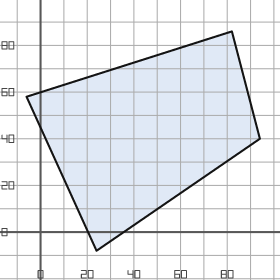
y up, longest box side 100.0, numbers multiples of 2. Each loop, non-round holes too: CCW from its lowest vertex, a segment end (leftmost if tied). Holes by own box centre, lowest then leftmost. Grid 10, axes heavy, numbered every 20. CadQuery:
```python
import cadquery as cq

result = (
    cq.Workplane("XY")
    .moveTo(24.0, -8.0)
    .lineTo(94.0, 40.0)
    .lineTo(82.0, 86.0)
    .lineTo(-6.0, 58.0)
    .close()
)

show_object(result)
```